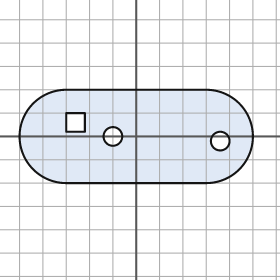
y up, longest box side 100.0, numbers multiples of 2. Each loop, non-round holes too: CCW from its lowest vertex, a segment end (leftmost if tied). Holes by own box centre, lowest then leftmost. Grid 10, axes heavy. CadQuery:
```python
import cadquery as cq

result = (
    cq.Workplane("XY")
    .moveTo(-30.0, -20.0)
    .lineTo(30.0, -20.0)
    .threePointArc((50.0, 0.0), (30.0, 20.0))
    .lineTo(-30.0, 20.0)
    .threePointArc((-50.0, 0.0), (-30.0, -20.0))
    .close()
    .moveTo(36.0, -2.0)
    .circle(4.0)
    .moveTo(-10.0, 0.0)
    .circle(4.0)
    .moveTo(-30.0, 2.0)
    .lineTo(-22.0, 2.0)
    .lineTo(-22.0, 10.0)
    .lineTo(-30.0, 10.0)
    .close()
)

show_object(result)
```